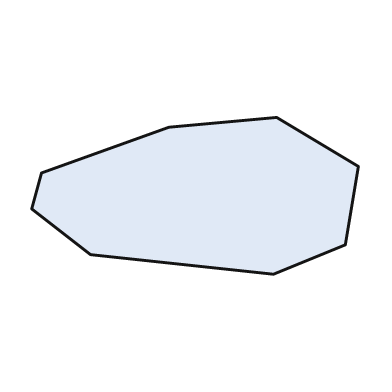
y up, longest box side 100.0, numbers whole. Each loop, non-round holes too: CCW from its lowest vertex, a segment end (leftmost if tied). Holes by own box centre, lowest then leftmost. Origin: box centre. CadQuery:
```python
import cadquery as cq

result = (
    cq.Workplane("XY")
    .moveTo(24.0, -24.0)
    .lineTo(46.0, -15.0)
    .lineTo(50.0, 9.0)
    .lineTo(25.0, 24.0)
    .lineTo(-8.0, 21.0)
    .lineTo(-47.0, 7.0)
    .lineTo(-50.0, -4.0)
    .lineTo(-32.0, -18.0)
    .close()
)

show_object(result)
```